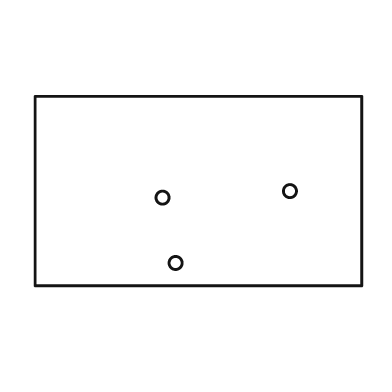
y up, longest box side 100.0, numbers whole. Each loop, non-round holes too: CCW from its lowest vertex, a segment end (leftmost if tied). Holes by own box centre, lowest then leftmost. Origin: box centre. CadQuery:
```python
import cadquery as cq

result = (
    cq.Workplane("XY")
    .moveTo(-50.0, -29.0)
    .lineTo(50.0, -29.0)
    .lineTo(50.0, 29.0)
    .lineTo(-50.0, 29.0)
    .close()
    .moveTo(-7.0, -22.0)
    .circle(2.0)
    .moveTo(-11.0, -2.0)
    .circle(2.0)
    .moveTo(28.0, 0.0)
    .circle(2.0)
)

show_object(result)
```